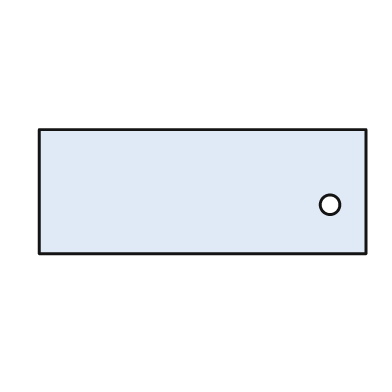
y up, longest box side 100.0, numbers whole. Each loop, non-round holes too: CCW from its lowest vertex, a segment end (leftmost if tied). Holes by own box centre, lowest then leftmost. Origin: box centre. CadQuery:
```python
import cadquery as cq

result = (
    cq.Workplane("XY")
    .moveTo(-50.0, -19.0)
    .lineTo(50.0, -19.0)
    .lineTo(50.0, 19.0)
    .lineTo(-50.0, 19.0)
    .close()
    .moveTo(39.0, -4.0)
    .circle(3.0)
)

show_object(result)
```